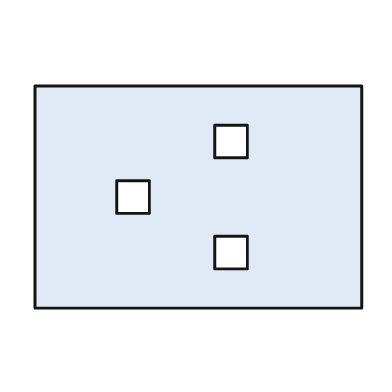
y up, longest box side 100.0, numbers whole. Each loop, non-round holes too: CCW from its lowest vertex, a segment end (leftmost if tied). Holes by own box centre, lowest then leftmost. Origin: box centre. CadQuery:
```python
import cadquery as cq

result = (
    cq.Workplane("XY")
    .moveTo(-50.0, -34.0)
    .lineTo(50.0, -34.0)
    .lineTo(50.0, 34.0)
    .lineTo(-50.0, 34.0)
    .close()
    .moveTo(5.0, -22.0)
    .lineTo(15.0, -22.0)
    .lineTo(15.0, -12.0)
    .lineTo(5.0, -12.0)
    .close()
    .moveTo(-25.0, -5.0)
    .lineTo(-15.0, -5.0)
    .lineTo(-15.0, 5.0)
    .lineTo(-25.0, 5.0)
    .close()
    .moveTo(5.0, 12.0)
    .lineTo(15.0, 12.0)
    .lineTo(15.0, 22.0)
    .lineTo(5.0, 22.0)
    .close()
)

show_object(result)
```